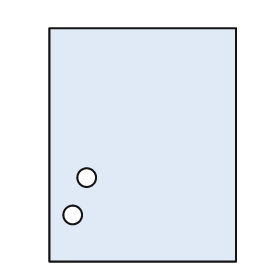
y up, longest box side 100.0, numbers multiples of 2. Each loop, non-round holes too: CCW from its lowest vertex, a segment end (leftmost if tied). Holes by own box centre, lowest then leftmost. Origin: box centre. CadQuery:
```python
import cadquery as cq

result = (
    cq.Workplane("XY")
    .moveTo(-40.0, -50.0)
    .lineTo(40.0, -50.0)
    .lineTo(40.0, 50.0)
    .lineTo(-40.0, 50.0)
    .close()
    .moveTo(-30.0, -30.0)
    .circle(4.0)
    .moveTo(-24.0, -14.0)
    .circle(4.0)
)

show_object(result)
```